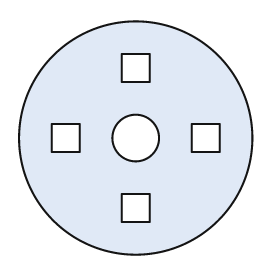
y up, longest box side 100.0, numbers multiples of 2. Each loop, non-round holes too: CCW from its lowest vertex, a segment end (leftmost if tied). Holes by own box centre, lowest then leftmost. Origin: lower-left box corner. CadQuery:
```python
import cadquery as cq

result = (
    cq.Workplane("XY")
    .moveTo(50.0, 50.0)
    .circle(50.0)
    .moveTo(44.0, 14.0)
    .lineTo(56.0, 14.0)
    .lineTo(56.0, 26.0)
    .lineTo(44.0, 26.0)
    .close()
    .moveTo(14.0, 44.0)
    .lineTo(26.0, 44.0)
    .lineTo(26.0, 56.0)
    .lineTo(14.0, 56.0)
    .close()
    .moveTo(50.0, 50.0)
    .circle(10.0)
    .moveTo(74.0, 44.0)
    .lineTo(86.0, 44.0)
    .lineTo(86.0, 56.0)
    .lineTo(74.0, 56.0)
    .close()
    .moveTo(44.0, 74.0)
    .lineTo(56.0, 74.0)
    .lineTo(56.0, 86.0)
    .lineTo(44.0, 86.0)
    .close()
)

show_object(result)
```